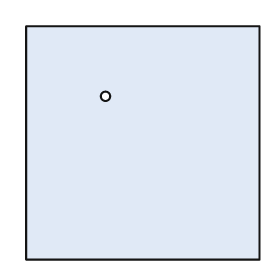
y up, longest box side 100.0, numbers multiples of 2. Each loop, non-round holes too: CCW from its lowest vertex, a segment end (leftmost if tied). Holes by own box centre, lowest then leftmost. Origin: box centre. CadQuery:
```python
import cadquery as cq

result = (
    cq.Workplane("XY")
    .moveTo(-50.0, -50.0)
    .lineTo(50.0, -50.0)
    .lineTo(50.0, 50.0)
    .lineTo(-50.0, 50.0)
    .close()
    .moveTo(-16.0, 20.0)
    .circle(2.0)
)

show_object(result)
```